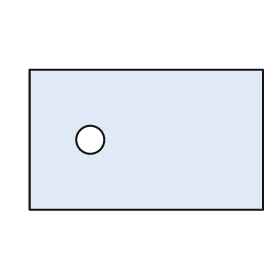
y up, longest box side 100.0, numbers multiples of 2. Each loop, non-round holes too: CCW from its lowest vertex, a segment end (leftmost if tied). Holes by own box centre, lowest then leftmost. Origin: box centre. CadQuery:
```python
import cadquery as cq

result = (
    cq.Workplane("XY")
    .moveTo(-50.0, -30.0)
    .lineTo(50.0, -30.0)
    .lineTo(50.0, 30.0)
    .lineTo(-50.0, 30.0)
    .close()
    .moveTo(-24.0, 0.0)
    .circle(6.0)
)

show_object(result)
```